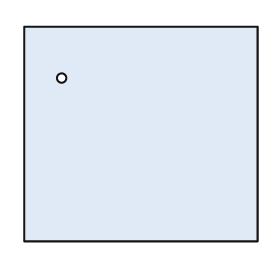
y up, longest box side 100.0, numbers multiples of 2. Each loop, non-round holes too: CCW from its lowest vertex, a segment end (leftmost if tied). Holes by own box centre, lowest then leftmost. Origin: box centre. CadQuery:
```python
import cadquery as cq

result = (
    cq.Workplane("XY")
    .moveTo(-50.0, -46.0)
    .lineTo(50.0, -46.0)
    .lineTo(50.0, 46.0)
    .lineTo(-50.0, 46.0)
    .close()
    .moveTo(-34.0, 24.0)
    .circle(2.0)
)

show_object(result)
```